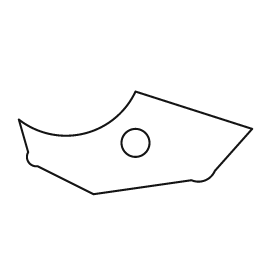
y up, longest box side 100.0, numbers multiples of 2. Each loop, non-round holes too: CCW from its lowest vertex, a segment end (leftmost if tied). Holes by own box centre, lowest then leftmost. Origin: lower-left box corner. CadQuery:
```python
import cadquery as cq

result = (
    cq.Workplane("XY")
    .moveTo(32.0, 0.0)
    .lineTo(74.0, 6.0)
    .threePointArc((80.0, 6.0), (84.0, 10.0))
    .lineTo(100.0, 28.0)
    .lineTo(50.0, 44.0)
    .threePointArc((28.0, 26.0), (0.0, 32.0))
    .lineTo(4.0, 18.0)
    .threePointArc((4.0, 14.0), (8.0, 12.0))
    .close()
    .moveTo(50.0, 22.0)
    .circle(6.0)
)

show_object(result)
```